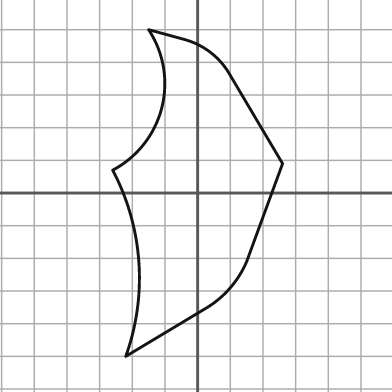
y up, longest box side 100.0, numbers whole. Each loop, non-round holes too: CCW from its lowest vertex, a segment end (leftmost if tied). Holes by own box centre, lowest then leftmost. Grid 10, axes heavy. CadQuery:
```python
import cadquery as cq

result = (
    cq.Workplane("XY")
    .moveTo(-22.0, -50.0)
    .lineTo(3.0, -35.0)
    .threePointArc((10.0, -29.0), (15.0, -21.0))
    .lineTo(26.0, 9.0)
    .lineTo(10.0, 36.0)
    .threePointArc((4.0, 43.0), (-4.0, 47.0))
    .lineTo(-15.0, 50.0)
    .threePointArc((-11.0, 26.0), (-26.0, 7.0))
    .threePointArc((-18.0, -21.0), (-22.0, -50.0))
    .close()
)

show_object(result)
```